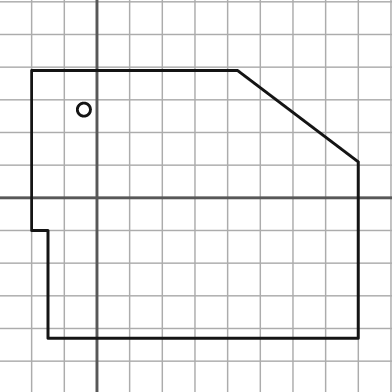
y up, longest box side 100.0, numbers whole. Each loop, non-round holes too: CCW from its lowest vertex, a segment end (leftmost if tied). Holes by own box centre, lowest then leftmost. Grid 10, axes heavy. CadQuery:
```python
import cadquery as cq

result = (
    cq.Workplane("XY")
    .moveTo(-15.0, -43.0)
    .lineTo(80.0, -43.0)
    .lineTo(80.0, 11.0)
    .lineTo(43.0, 39.0)
    .lineTo(-20.0, 39.0)
    .lineTo(-20.0, -10.0)
    .lineTo(-15.0, -10.0)
    .close()
    .moveTo(-4.0, 27.0)
    .circle(2.0)
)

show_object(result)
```